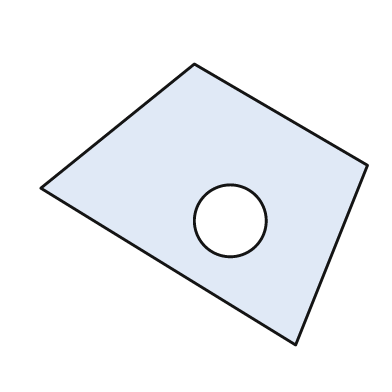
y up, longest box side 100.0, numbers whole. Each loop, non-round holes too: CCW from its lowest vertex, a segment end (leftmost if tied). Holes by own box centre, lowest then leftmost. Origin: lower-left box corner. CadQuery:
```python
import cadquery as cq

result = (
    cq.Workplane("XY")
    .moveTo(78.0, 0.0)
    .lineTo(100.0, 55.0)
    .lineTo(47.0, 86.0)
    .lineTo(0.0, 48.0)
    .close()
    .moveTo(58.0, 38.0)
    .circle(11.0)
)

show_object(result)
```